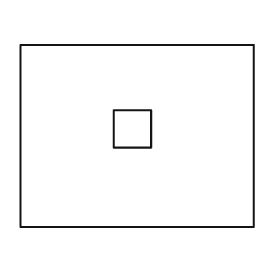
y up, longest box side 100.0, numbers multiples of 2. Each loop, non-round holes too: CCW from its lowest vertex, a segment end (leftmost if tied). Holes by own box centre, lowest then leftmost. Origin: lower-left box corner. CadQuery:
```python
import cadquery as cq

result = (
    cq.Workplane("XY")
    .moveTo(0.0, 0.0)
    .lineTo(100.0, 0.0)
    .lineTo(100.0, 78.0)
    .lineTo(0.0, 78.0)
    .close()
    .moveTo(40.0, 34.0)
    .lineTo(56.0, 34.0)
    .lineTo(56.0, 50.0)
    .lineTo(40.0, 50.0)
    .close()
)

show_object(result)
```